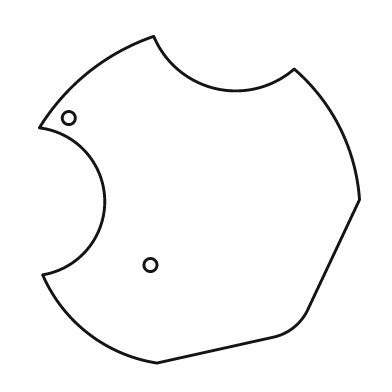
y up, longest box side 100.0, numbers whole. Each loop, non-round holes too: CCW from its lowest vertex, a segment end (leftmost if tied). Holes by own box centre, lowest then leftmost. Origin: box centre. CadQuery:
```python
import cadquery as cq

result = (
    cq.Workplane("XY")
    .moveTo(-13.0, -50.0)
    .lineTo(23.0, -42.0)
    .threePointArc((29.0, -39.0), (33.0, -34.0))
    .lineTo(49.0, 0.0)
    .threePointArc((43.0, 22.0), (29.0, 40.0))
    .threePointArc((5.0, 34.0), (-14.0, 50.0))
    .threePointArc((-34.0, 39.0), (-49.0, 22.0))
    .threePointArc((-29.0, 0.0), (-48.0, -23.0))
    .threePointArc((-34.0, -41.0), (-13.0, -50.0))
    .close()
    .moveTo(-15.0, -20.0)
    .circle(2.0)
    .moveTo(-40.0, 25.0)
    .circle(2.0)
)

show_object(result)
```